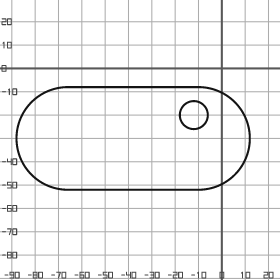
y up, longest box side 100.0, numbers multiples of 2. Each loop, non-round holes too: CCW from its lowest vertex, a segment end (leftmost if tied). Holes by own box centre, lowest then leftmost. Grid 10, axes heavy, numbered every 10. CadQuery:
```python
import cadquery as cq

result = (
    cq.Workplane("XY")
    .moveTo(-66.0, -52.0)
    .lineTo(-10.0, -52.0)
    .threePointArc((12.0, -30.0), (-10.0, -8.0))
    .lineTo(-66.0, -8.0)
    .threePointArc((-88.0, -30.0), (-66.0, -52.0))
    .close()
    .moveTo(-12.0, -20.0)
    .circle(6.0)
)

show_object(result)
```